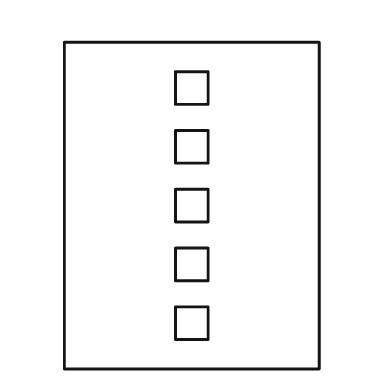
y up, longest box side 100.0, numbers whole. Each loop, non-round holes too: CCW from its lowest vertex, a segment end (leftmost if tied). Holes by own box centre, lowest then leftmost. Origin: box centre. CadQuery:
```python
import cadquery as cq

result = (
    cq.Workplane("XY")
    .moveTo(-39.0, -50.0)
    .lineTo(39.0, -50.0)
    .lineTo(39.0, 50.0)
    .lineTo(-39.0, 50.0)
    .close()
    .moveTo(-5.0, -41.0)
    .lineTo(5.0, -41.0)
    .lineTo(5.0, -31.0)
    .lineTo(-5.0, -31.0)
    .close()
    .moveTo(-5.0, -23.0)
    .lineTo(5.0, -23.0)
    .lineTo(5.0, -13.0)
    .lineTo(-5.0, -13.0)
    .close()
    .moveTo(-5.0, -5.0)
    .lineTo(5.0, -5.0)
    .lineTo(5.0, 5.0)
    .lineTo(-5.0, 5.0)
    .close()
    .moveTo(-5.0, 13.0)
    .lineTo(5.0, 13.0)
    .lineTo(5.0, 23.0)
    .lineTo(-5.0, 23.0)
    .close()
    .moveTo(-5.0, 31.0)
    .lineTo(5.0, 31.0)
    .lineTo(5.0, 41.0)
    .lineTo(-5.0, 41.0)
    .close()
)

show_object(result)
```